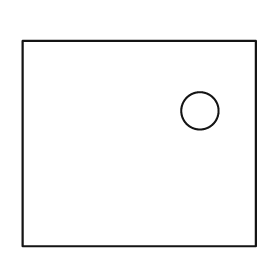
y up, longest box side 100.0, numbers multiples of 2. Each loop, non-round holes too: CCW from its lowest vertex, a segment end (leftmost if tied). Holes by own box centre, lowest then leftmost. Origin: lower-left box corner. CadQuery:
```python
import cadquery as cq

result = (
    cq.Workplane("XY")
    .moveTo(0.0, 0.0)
    .lineTo(100.0, 0.0)
    .lineTo(100.0, 88.0)
    .lineTo(0.0, 88.0)
    .close()
    .moveTo(76.0, 58.0)
    .circle(8.0)
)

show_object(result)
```